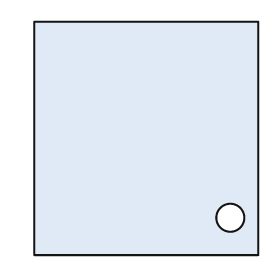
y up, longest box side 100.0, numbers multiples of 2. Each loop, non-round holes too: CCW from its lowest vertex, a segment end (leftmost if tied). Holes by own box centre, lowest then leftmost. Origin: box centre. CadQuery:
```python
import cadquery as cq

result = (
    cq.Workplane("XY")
    .moveTo(-48.0, -50.0)
    .lineTo(48.0, -50.0)
    .lineTo(48.0, 50.0)
    .lineTo(-48.0, 50.0)
    .close()
    .moveTo(36.0, -34.0)
    .circle(6.0)
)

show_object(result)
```